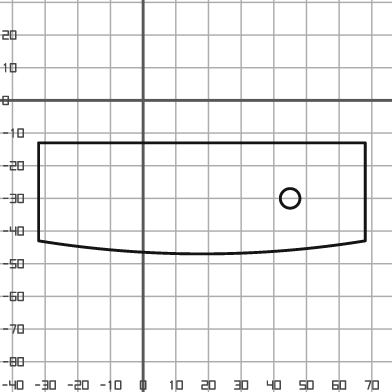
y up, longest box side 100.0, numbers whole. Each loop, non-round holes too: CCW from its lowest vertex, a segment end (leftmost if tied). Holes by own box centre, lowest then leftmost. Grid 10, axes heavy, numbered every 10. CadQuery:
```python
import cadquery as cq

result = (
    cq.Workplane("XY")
    .moveTo(-32.0, -43.0)
    .threePointArc((18.0, -47.0), (68.0, -43.0))
    .lineTo(68.0, -13.0)
    .lineTo(-32.0, -13.0)
    .close()
    .moveTo(45.0, -30.0)
    .circle(3.0)
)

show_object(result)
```